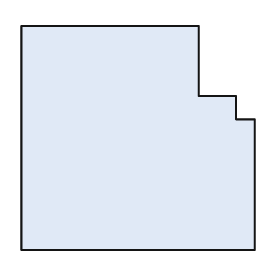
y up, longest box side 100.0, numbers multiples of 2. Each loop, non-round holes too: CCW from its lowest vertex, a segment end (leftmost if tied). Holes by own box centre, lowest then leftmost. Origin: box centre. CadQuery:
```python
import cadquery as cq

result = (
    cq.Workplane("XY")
    .moveTo(-50.0, -48.0)
    .lineTo(50.0, -48.0)
    .lineTo(50.0, 8.0)
    .lineTo(42.0, 8.0)
    .lineTo(42.0, 18.0)
    .lineTo(26.0, 18.0)
    .lineTo(26.0, 48.0)
    .lineTo(-50.0, 48.0)
    .close()
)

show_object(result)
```